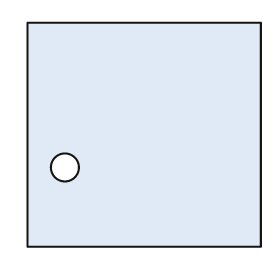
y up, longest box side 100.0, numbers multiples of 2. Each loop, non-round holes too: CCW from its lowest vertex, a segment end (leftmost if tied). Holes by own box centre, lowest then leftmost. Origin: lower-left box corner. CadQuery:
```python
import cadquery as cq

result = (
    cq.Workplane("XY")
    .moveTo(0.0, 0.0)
    .lineTo(100.0, 0.0)
    .lineTo(100.0, 96.0)
    .lineTo(0.0, 96.0)
    .close()
    .moveTo(16.0, 34.0)
    .circle(6.0)
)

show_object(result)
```